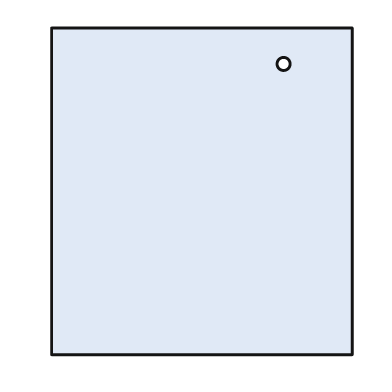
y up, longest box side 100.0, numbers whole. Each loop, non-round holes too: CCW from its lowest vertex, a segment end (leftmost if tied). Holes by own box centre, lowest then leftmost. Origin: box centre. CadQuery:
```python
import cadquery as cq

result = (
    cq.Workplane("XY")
    .moveTo(-46.0, -50.0)
    .lineTo(46.0, -50.0)
    .lineTo(46.0, 50.0)
    .lineTo(-46.0, 50.0)
    .close()
    .moveTo(25.0, 39.0)
    .circle(2.0)
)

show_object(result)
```